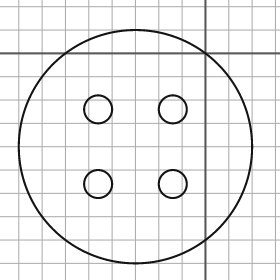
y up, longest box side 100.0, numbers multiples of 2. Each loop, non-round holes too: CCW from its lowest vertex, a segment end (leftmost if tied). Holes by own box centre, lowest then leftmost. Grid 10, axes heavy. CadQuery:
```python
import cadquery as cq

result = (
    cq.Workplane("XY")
    .moveTo(-30.0, -40.0)
    .circle(50.0)
    .moveTo(-46.0, -56.0)
    .circle(6.0)
    .moveTo(-14.0, -56.0)
    .circle(6.0)
    .moveTo(-46.0, -24.0)
    .circle(6.0)
    .moveTo(-14.0, -24.0)
    .circle(6.0)
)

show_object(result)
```